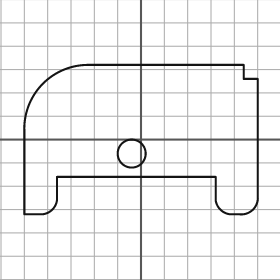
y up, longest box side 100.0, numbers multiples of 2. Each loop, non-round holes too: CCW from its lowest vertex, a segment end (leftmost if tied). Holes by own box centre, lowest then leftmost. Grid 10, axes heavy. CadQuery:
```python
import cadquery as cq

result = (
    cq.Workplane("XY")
    .moveTo(-50.0, -32.0)
    .lineTo(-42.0, -32.0)
    .threePointArc((-38.0, -30.0), (-36.0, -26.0))
    .lineTo(-36.0, -16.0)
    .lineTo(32.0, -16.0)
    .lineTo(32.0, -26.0)
    .threePointArc((34.0, -30.0), (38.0, -32.0))
    .lineTo(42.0, -32.0)
    .threePointArc((48.0, -30.0), (50.0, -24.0))
    .lineTo(50.0, 26.0)
    .lineTo(44.0, 26.0)
    .lineTo(44.0, 32.0)
    .lineTo(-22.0, 32.0)
    .threePointArc((-42.0, 24.0), (-50.0, 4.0))
    .close()
    .moveTo(-4.0, -6.0)
    .circle(6.0)
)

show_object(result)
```